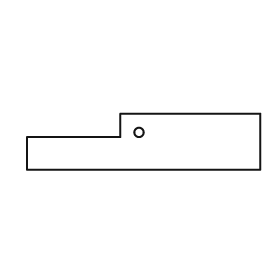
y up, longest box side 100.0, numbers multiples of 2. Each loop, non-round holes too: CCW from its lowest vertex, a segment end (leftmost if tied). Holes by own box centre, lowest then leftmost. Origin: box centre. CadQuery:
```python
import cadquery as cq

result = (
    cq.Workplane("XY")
    .moveTo(-50.0, -12.0)
    .lineTo(50.0, -12.0)
    .lineTo(50.0, 12.0)
    .lineTo(-10.0, 12.0)
    .lineTo(-10.0, 2.0)
    .lineTo(-50.0, 2.0)
    .close()
    .moveTo(-2.0, 4.0)
    .circle(2.0)
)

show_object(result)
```